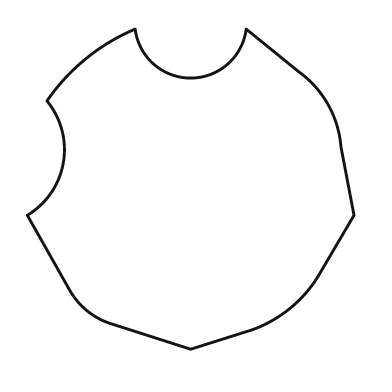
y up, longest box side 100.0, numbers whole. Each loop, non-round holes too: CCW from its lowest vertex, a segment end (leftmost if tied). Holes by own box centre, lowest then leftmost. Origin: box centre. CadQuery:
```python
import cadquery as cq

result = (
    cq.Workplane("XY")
    .moveTo(0.0, -49.0)
    .lineTo(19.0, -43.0)
    .threePointArc((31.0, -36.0), (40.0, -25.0))
    .lineTo(50.0, -8.0)
    .lineTo(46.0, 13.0)
    .threePointArc((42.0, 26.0), (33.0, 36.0))
    .lineTo(17.0, 49.0)
    .threePointArc((0.0, 34.0), (-17.0, 49.0))
    .threePointArc((-32.0, 40.0), (-44.0, 27.0))
    .threePointArc((-39.0, 8.0), (-50.0, -8.0))
    .lineTo(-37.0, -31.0)
    .threePointArc((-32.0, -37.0), (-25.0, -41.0))
    .close()
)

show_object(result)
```